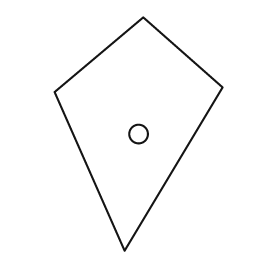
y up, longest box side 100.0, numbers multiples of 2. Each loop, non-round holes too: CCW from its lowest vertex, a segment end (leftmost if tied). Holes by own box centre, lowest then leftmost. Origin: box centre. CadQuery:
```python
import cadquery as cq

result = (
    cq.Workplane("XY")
    .moveTo(-6.0, -50.0)
    .lineTo(36.0, 20.0)
    .lineTo(2.0, 50.0)
    .lineTo(-36.0, 18.0)
    .close()
    .moveTo(0.0, 0.0)
    .circle(4.0)
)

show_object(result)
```